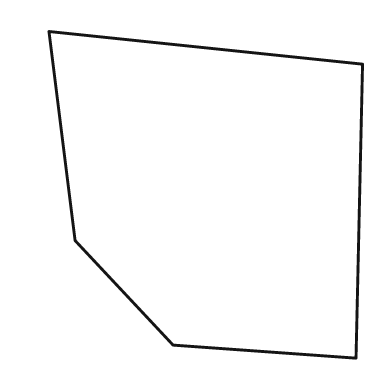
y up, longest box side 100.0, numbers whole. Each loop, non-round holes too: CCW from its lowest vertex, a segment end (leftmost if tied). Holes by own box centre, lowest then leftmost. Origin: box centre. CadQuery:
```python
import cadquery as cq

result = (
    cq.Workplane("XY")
    .moveTo(46.0, -50.0)
    .lineTo(48.0, 40.0)
    .lineTo(-48.0, 50.0)
    .lineTo(-40.0, -14.0)
    .lineTo(-10.0, -46.0)
    .close()
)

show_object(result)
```